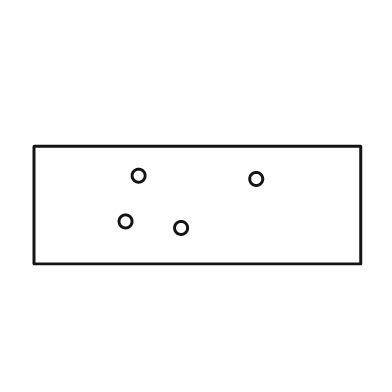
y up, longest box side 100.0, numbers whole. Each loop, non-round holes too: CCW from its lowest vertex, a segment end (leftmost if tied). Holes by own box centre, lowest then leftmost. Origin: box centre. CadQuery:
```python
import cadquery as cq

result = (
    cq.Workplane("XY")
    .moveTo(-50.0, -18.0)
    .lineTo(50.0, -18.0)
    .lineTo(50.0, 18.0)
    .lineTo(-50.0, 18.0)
    .close()
    .moveTo(-5.0, -7.0)
    .circle(2.0)
    .moveTo(-22.0, -5.0)
    .circle(2.0)
    .moveTo(18.0, 8.0)
    .circle(2.0)
    .moveTo(-18.0, 9.0)
    .circle(2.0)
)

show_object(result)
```